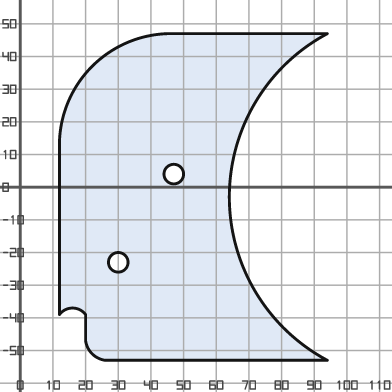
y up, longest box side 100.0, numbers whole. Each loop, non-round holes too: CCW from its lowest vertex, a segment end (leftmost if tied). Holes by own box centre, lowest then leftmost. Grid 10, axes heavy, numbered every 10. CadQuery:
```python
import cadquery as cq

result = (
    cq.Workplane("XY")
    .moveTo(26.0, -53.0)
    .lineTo(94.0, -53.0)
    .threePointArc((64.0, -3.0), (94.0, 47.0))
    .lineTo(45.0, 47.0)
    .threePointArc((22.0, 37.0), (12.0, 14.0))
    .lineTo(12.0, -39.0)
    .threePointArc((16.0, -37.0), (20.0, -39.0))
    .lineTo(20.0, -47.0)
    .threePointArc((22.0, -51.0), (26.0, -53.0))
    .close()
    .moveTo(30.0, -23.0)
    .circle(3.0)
    .moveTo(47.0, 4.0)
    .circle(3.0)
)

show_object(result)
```